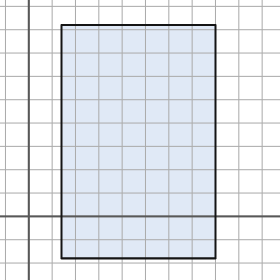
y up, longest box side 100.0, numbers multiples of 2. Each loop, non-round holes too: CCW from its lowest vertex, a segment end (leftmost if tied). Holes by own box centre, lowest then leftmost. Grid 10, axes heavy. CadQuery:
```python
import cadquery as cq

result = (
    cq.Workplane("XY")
    .moveTo(14.0, -18.0)
    .lineTo(80.0, -18.0)
    .lineTo(80.0, 82.0)
    .lineTo(14.0, 82.0)
    .close()
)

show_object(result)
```